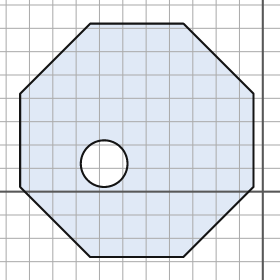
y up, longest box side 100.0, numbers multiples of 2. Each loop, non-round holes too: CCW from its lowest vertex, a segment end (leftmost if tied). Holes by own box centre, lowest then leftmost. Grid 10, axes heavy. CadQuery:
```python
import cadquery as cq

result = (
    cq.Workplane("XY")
    .moveTo(-74.0, -28.0)
    .lineTo(-34.0, -28.0)
    .lineTo(-4.0, 2.0)
    .lineTo(-4.0, 42.0)
    .lineTo(-34.0, 72.0)
    .lineTo(-74.0, 72.0)
    .lineTo(-104.0, 42.0)
    .lineTo(-104.0, 2.0)
    .close()
    .moveTo(-68.0, 12.0)
    .circle(10.0)
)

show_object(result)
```